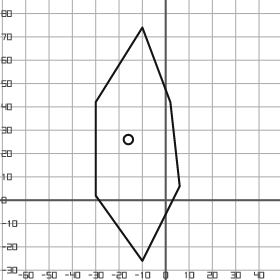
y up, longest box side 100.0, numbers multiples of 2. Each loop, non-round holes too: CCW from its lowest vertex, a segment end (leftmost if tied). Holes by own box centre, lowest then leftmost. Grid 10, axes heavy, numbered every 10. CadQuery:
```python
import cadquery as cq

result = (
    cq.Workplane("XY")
    .moveTo(-10.0, -26.0)
    .lineTo(6.0, 6.0)
    .lineTo(2.0, 42.0)
    .lineTo(-10.0, 74.0)
    .lineTo(-30.0, 42.0)
    .lineTo(-30.0, 2.0)
    .close()
    .moveTo(-16.0, 26.0)
    .circle(2.0)
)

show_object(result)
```